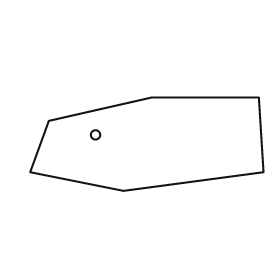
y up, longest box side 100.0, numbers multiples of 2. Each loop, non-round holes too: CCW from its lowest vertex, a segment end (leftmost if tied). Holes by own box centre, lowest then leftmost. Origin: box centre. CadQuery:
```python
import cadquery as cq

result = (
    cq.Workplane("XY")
    .moveTo(-10.0, -20.0)
    .lineTo(50.0, -12.0)
    .lineTo(48.0, 20.0)
    .lineTo(2.0, 20.0)
    .lineTo(-42.0, 10.0)
    .lineTo(-50.0, -12.0)
    .close()
    .moveTo(-22.0, 4.0)
    .circle(2.0)
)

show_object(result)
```